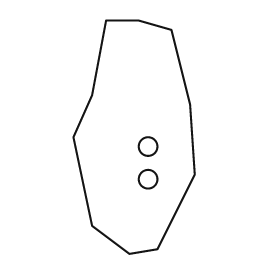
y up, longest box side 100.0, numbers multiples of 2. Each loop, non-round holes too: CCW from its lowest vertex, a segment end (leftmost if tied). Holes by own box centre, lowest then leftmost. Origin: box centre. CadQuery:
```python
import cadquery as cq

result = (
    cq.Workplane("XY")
    .moveTo(-2.0, -50.0)
    .lineTo(10.0, -48.0)
    .lineTo(26.0, -16.0)
    .lineTo(24.0, 14.0)
    .lineTo(16.0, 46.0)
    .lineTo(2.0, 50.0)
    .lineTo(-12.0, 50.0)
    .lineTo(-18.0, 18.0)
    .lineTo(-26.0, 0.0)
    .lineTo(-18.0, -38.0)
    .close()
    .moveTo(6.0, -18.0)
    .circle(4.0)
    .moveTo(6.0, -4.0)
    .circle(4.0)
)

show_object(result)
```